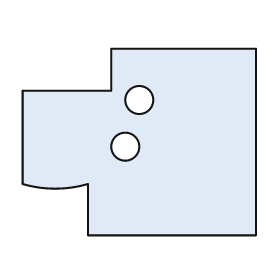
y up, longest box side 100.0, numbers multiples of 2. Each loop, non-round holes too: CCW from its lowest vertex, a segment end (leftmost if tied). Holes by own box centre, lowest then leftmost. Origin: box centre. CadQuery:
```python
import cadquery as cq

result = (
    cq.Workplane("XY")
    .moveTo(-22.0, -40.0)
    .lineTo(50.0, -40.0)
    .lineTo(50.0, 40.0)
    .lineTo(-12.0, 40.0)
    .lineTo(-12.0, 22.0)
    .lineTo(-50.0, 22.0)
    .lineTo(-50.0, -18.0)
    .threePointArc((-36.0, -20.0), (-22.0, -18.0))
    .close()
    .moveTo(-6.0, -2.0)
    .circle(6.0)
    .moveTo(0.0, 18.0)
    .circle(6.0)
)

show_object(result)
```